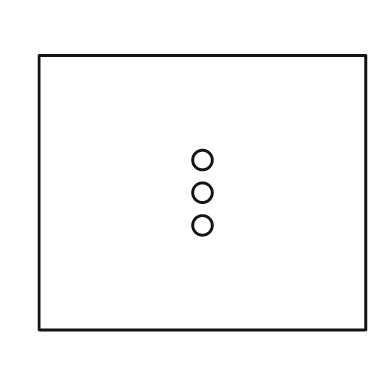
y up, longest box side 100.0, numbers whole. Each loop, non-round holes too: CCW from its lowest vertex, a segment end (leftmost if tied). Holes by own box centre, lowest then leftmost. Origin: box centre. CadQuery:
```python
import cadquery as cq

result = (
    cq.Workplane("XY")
    .moveTo(-50.0, -42.0)
    .lineTo(50.0, -42.0)
    .lineTo(50.0, 42.0)
    .lineTo(-50.0, 42.0)
    .close()
    .moveTo(0.0, -10.0)
    .circle(3.0)
    .moveTo(0.0, 0.0)
    .circle(3.0)
    .moveTo(0.0, 10.0)
    .circle(3.0)
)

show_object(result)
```